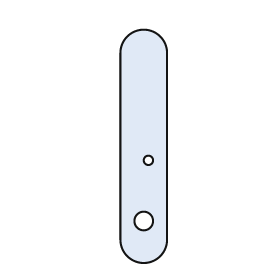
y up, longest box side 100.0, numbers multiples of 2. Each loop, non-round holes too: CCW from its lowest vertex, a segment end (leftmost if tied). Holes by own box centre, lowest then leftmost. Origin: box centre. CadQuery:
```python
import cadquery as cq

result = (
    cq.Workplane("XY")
    .moveTo(-10.0, -40.0)
    .threePointArc((0.0, -50.0), (10.0, -40.0))
    .lineTo(10.0, 40.0)
    .threePointArc((0.0, 50.0), (-10.0, 40.0))
    .close()
    .moveTo(0.0, -32.0)
    .circle(4.0)
    .moveTo(2.0, -6.0)
    .circle(2.0)
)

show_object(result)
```